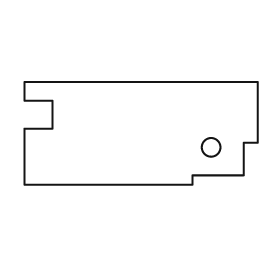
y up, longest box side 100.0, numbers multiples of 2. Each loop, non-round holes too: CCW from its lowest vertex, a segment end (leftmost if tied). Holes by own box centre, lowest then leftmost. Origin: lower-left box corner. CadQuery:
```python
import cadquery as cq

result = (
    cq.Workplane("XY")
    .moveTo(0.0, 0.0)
    .lineTo(72.0, 0.0)
    .lineTo(72.0, 4.0)
    .lineTo(94.0, 4.0)
    .lineTo(94.0, 18.0)
    .lineTo(100.0, 18.0)
    .lineTo(100.0, 44.0)
    .lineTo(0.0, 44.0)
    .lineTo(0.0, 36.0)
    .lineTo(12.0, 36.0)
    .lineTo(12.0, 24.0)
    .lineTo(0.0, 24.0)
    .close()
    .moveTo(80.0, 16.0)
    .circle(4.0)
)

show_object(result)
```